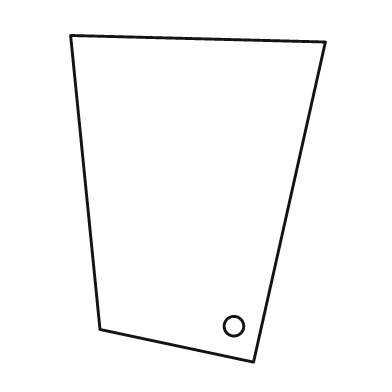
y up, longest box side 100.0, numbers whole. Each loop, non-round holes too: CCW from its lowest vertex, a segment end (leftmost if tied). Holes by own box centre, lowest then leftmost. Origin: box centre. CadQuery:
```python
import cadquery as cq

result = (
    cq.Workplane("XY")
    .moveTo(17.0, -50.0)
    .lineTo(39.0, 48.0)
    .lineTo(-39.0, 50.0)
    .lineTo(-30.0, -40.0)
    .close()
    .moveTo(11.0, -39.0)
    .circle(3.0)
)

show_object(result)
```